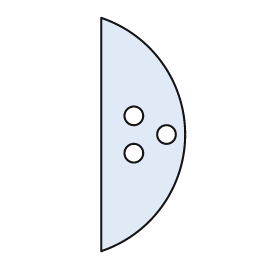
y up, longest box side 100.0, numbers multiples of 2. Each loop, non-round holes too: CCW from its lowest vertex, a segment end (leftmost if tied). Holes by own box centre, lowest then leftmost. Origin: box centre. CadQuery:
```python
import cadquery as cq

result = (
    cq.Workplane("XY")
    .moveTo(-18.0, -50.0)
    .threePointArc((18.0, 0.0), (-18.0, 50.0))
    .close()
    .moveTo(-4.0, -8.0)
    .circle(4.0)
    .moveTo(10.0, 0.0)
    .circle(4.0)
    .moveTo(-4.0, 8.0)
    .circle(4.0)
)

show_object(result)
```